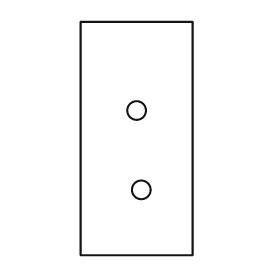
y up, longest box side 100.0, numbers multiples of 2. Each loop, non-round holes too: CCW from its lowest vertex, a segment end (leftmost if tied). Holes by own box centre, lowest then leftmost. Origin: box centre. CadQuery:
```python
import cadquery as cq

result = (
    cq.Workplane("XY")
    .moveTo(-24.0, -50.0)
    .lineTo(24.0, -50.0)
    .lineTo(24.0, 50.0)
    .lineTo(-24.0, 50.0)
    .close()
    .moveTo(2.0, -22.0)
    .circle(4.0)
    .moveTo(0.0, 12.0)
    .circle(4.0)
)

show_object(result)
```